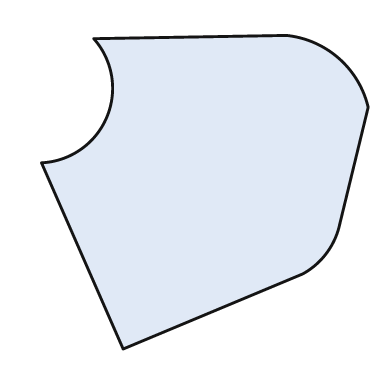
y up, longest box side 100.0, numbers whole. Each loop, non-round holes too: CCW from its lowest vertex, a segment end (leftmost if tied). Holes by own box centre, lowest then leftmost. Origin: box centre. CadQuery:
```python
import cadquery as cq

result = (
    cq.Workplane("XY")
    .moveTo(-25.0, -48.0)
    .lineTo(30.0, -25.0)
    .threePointArc((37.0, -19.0), (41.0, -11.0))
    .lineTo(50.0, 26.0)
    .threePointArc((41.0, 41.0), (25.0, 48.0))
    .lineTo(-34.0, 47.0)
    .threePointArc((-30.0, 23.0), (-50.0, 9.0))
    .close()
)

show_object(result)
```